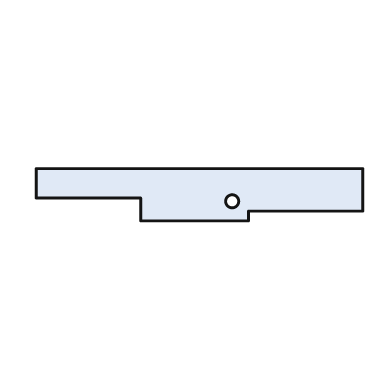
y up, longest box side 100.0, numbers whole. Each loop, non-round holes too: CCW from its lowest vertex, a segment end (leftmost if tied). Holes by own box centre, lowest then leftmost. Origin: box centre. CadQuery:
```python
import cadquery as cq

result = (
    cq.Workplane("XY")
    .moveTo(-18.0, -8.0)
    .lineTo(15.0, -8.0)
    .lineTo(15.0, -5.0)
    .lineTo(50.0, -5.0)
    .lineTo(50.0, 8.0)
    .lineTo(-50.0, 8.0)
    .lineTo(-50.0, -1.0)
    .lineTo(-18.0, -1.0)
    .close()
    .moveTo(10.0, -2.0)
    .circle(2.0)
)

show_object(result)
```